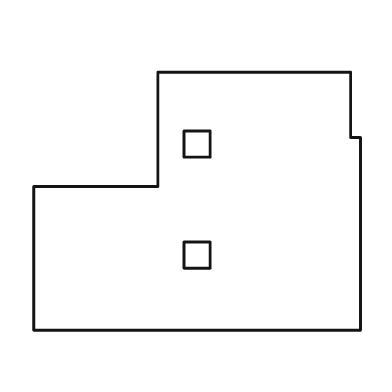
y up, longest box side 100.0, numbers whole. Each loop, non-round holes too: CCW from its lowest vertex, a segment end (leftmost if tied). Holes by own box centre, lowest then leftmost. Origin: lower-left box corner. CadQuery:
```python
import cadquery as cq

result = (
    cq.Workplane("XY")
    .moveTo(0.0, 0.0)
    .lineTo(100.0, 0.0)
    .lineTo(100.0, 59.0)
    .lineTo(97.0, 59.0)
    .lineTo(97.0, 79.0)
    .lineTo(38.0, 79.0)
    .lineTo(38.0, 44.0)
    .lineTo(0.0, 44.0)
    .close()
    .moveTo(46.0, 19.0)
    .lineTo(54.0, 19.0)
    .lineTo(54.0, 27.0)
    .lineTo(46.0, 27.0)
    .close()
    .moveTo(46.0, 53.0)
    .lineTo(54.0, 53.0)
    .lineTo(54.0, 61.0)
    .lineTo(46.0, 61.0)
    .close()
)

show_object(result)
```